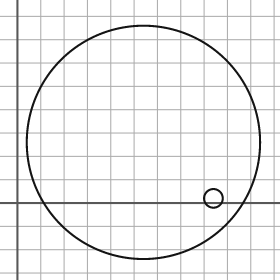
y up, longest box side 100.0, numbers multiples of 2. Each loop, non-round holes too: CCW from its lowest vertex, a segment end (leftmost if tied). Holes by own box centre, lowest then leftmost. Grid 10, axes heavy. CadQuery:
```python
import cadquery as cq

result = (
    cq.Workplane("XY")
    .moveTo(54.0, 26.0)
    .circle(50.0)
    .moveTo(84.0, 2.0)
    .circle(4.0)
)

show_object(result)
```